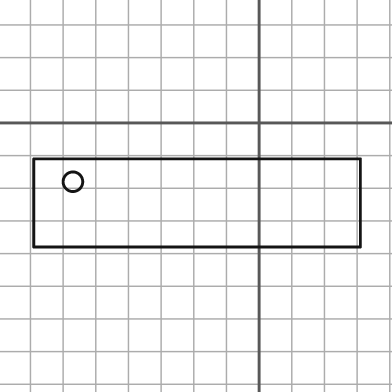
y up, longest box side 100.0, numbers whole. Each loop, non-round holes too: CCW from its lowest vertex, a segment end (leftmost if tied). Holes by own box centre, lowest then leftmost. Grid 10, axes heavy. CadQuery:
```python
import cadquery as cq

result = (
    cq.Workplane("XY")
    .moveTo(-69.0, -38.0)
    .lineTo(31.0, -38.0)
    .lineTo(31.0, -11.0)
    .lineTo(-69.0, -11.0)
    .close()
    .moveTo(-57.0, -18.0)
    .circle(3.0)
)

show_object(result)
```